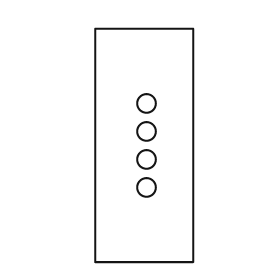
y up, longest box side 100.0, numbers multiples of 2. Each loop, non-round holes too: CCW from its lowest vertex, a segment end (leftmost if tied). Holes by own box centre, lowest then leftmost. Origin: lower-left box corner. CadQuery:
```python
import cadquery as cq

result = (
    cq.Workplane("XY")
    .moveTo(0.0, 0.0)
    .lineTo(42.0, 0.0)
    .lineTo(42.0, 100.0)
    .lineTo(0.0, 100.0)
    .close()
    .moveTo(22.0, 32.0)
    .circle(4.0)
    .moveTo(22.0, 44.0)
    .circle(4.0)
    .moveTo(22.0, 56.0)
    .circle(4.0)
    .moveTo(22.0, 68.0)
    .circle(4.0)
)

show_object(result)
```